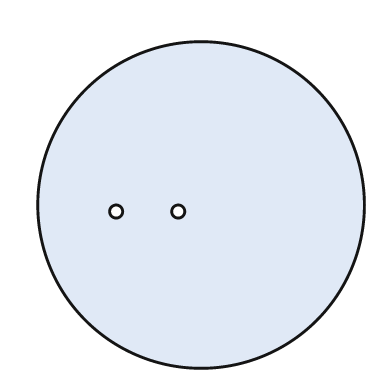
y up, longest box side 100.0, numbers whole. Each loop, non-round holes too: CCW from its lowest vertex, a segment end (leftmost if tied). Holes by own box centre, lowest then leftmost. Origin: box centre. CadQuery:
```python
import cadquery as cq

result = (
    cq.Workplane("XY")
    .moveTo(0.0, 0.0)
    .circle(50.0)
    .moveTo(-26.0, -2.0)
    .circle(2.0)
    .moveTo(-7.0, -2.0)
    .circle(2.0)
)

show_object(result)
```